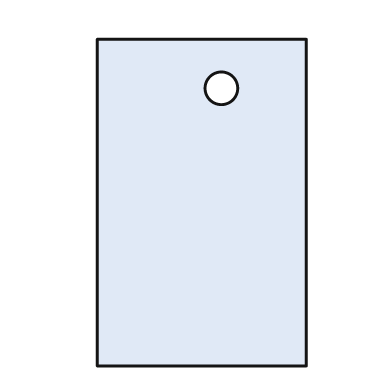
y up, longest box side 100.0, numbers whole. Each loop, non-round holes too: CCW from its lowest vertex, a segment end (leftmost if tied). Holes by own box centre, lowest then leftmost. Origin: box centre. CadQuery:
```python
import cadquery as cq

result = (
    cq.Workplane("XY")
    .moveTo(-32.0, -50.0)
    .lineTo(32.0, -50.0)
    .lineTo(32.0, 50.0)
    .lineTo(-32.0, 50.0)
    .close()
    .moveTo(6.0, 35.0)
    .circle(5.0)
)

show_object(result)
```